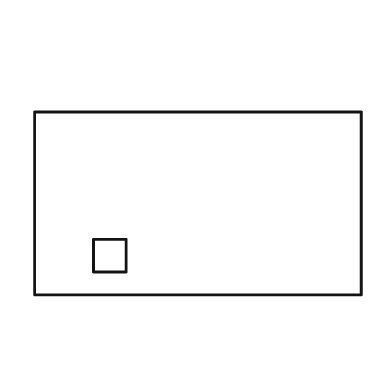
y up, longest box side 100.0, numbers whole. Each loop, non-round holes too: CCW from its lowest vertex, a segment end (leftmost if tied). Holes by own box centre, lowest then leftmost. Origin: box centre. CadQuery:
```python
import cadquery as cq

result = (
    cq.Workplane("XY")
    .moveTo(-50.0, -28.0)
    .lineTo(50.0, -28.0)
    .lineTo(50.0, 28.0)
    .lineTo(-50.0, 28.0)
    .close()
    .moveTo(-32.0, -21.0)
    .lineTo(-22.0, -21.0)
    .lineTo(-22.0, -11.0)
    .lineTo(-32.0, -11.0)
    .close()
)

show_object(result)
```